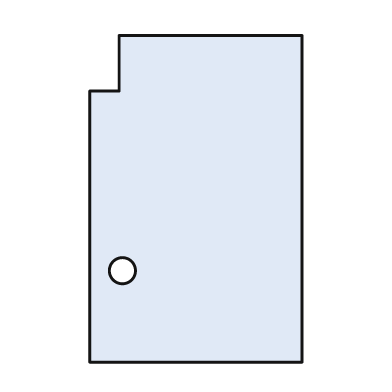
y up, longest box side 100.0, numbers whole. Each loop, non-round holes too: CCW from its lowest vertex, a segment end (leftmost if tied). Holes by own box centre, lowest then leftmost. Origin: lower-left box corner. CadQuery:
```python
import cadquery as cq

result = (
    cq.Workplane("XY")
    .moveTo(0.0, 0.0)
    .lineTo(65.0, 0.0)
    .lineTo(65.0, 100.0)
    .lineTo(9.0, 100.0)
    .lineTo(9.0, 83.0)
    .lineTo(0.0, 83.0)
    .close()
    .moveTo(10.0, 28.0)
    .circle(4.0)
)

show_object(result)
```